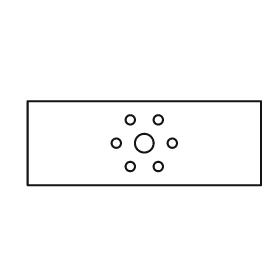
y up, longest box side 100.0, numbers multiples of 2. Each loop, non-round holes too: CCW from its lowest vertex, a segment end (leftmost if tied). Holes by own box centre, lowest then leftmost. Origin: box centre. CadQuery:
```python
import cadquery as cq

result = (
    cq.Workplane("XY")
    .moveTo(-50.0, -18.0)
    .lineTo(50.0, -18.0)
    .lineTo(50.0, 18.0)
    .lineTo(-50.0, 18.0)
    .close()
    .moveTo(-6.0, -10.0)
    .circle(2.0)
    .moveTo(6.0, -10.0)
    .circle(2.0)
    .moveTo(-12.0, 0.0)
    .circle(2.0)
    .moveTo(0.0, 0.0)
    .circle(4.0)
    .moveTo(12.0, 0.0)
    .circle(2.0)
    .moveTo(-6.0, 10.0)
    .circle(2.0)
    .moveTo(6.0, 10.0)
    .circle(2.0)
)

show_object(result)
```